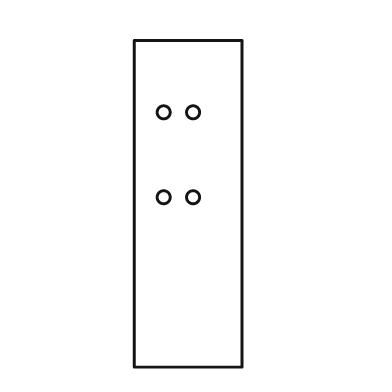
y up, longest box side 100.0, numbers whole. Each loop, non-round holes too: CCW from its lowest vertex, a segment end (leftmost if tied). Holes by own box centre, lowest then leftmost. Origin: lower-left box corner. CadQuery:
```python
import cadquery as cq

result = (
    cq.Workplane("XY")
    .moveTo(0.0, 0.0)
    .lineTo(33.0, 0.0)
    .lineTo(33.0, 100.0)
    .lineTo(0.0, 100.0)
    .close()
    .moveTo(9.0, 52.0)
    .circle(2.0)
    .moveTo(18.0, 52.0)
    .circle(2.0)
    .moveTo(9.0, 78.0)
    .circle(2.0)
    .moveTo(18.0, 78.0)
    .circle(2.0)
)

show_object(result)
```